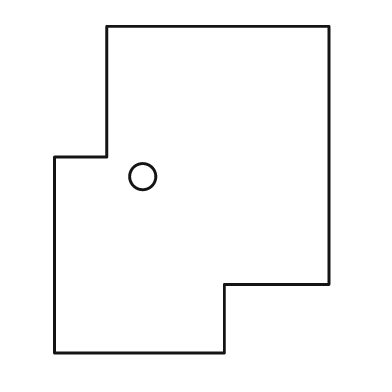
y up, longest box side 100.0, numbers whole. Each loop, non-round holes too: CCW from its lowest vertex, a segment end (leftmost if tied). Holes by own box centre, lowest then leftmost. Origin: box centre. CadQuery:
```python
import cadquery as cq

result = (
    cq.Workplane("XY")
    .moveTo(-42.0, -50.0)
    .lineTo(10.0, -50.0)
    .lineTo(10.0, -29.0)
    .lineTo(42.0, -29.0)
    .lineTo(42.0, 50.0)
    .lineTo(-26.0, 50.0)
    .lineTo(-26.0, 10.0)
    .lineTo(-42.0, 10.0)
    .close()
    .moveTo(-15.0, 4.0)
    .circle(4.0)
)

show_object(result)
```